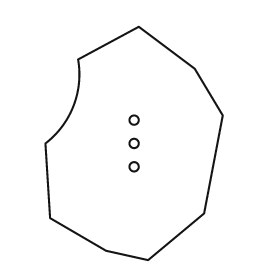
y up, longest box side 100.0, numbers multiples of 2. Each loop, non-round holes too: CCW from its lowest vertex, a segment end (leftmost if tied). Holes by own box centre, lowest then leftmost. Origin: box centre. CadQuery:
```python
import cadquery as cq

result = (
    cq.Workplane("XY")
    .moveTo(6.0, -50.0)
    .lineTo(30.0, -30.0)
    .lineTo(38.0, 12.0)
    .lineTo(26.0, 32.0)
    .lineTo(2.0, 50.0)
    .lineTo(-24.0, 36.0)
    .threePointArc((-26.0, 16.0), (-38.0, 0.0))
    .lineTo(-36.0, -32.0)
    .lineTo(-12.0, -46.0)
    .close()
    .moveTo(0.0, -10.0)
    .circle(2.0)
    .moveTo(0.0, 0.0)
    .circle(2.0)
    .moveTo(0.0, 10.0)
    .circle(2.0)
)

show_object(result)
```